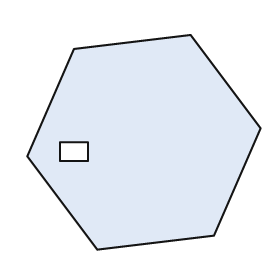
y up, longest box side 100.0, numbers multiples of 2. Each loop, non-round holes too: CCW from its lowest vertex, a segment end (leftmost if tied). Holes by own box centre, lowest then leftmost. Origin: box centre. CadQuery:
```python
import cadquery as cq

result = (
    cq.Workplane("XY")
    .moveTo(-20.0, -46.0)
    .lineTo(30.0, -40.0)
    .lineTo(50.0, 6.0)
    .lineTo(20.0, 46.0)
    .lineTo(-30.0, 40.0)
    .lineTo(-50.0, -6.0)
    .close()
    .moveTo(-36.0, -8.0)
    .lineTo(-24.0, -8.0)
    .lineTo(-24.0, 0.0)
    .lineTo(-36.0, 0.0)
    .close()
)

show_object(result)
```